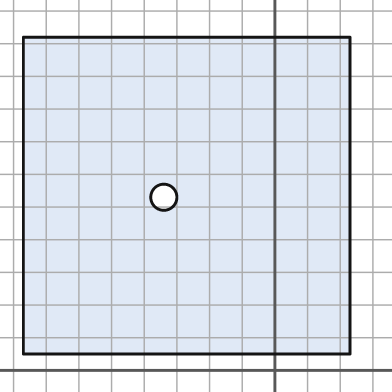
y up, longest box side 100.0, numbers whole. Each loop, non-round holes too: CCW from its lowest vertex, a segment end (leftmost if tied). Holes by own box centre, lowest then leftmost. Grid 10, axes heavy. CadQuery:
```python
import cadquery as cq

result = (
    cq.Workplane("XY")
    .moveTo(-77.0, 5.0)
    .lineTo(23.0, 5.0)
    .lineTo(23.0, 102.0)
    .lineTo(-77.0, 102.0)
    .close()
    .moveTo(-34.0, 53.0)
    .circle(4.0)
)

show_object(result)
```